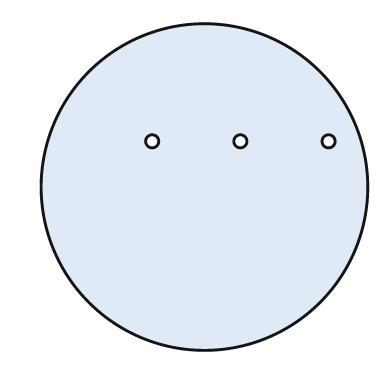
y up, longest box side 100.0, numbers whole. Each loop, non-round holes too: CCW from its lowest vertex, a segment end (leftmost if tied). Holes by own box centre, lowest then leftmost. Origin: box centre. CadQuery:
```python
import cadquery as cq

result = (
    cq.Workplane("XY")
    .moveTo(0.0, 0.0)
    .circle(50.0)
    .moveTo(-16.0, 14.0)
    .circle(2.0)
    .moveTo(11.0, 14.0)
    .circle(2.0)
    .moveTo(38.0, 14.0)
    .circle(2.0)
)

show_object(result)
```